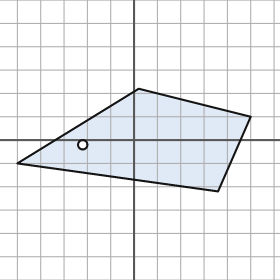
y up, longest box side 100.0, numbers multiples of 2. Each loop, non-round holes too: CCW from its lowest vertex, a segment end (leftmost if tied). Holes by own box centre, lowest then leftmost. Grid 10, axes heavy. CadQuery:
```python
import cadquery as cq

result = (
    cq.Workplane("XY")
    .moveTo(36.0, -22.0)
    .lineTo(50.0, 10.0)
    .lineTo(2.0, 22.0)
    .lineTo(-50.0, -10.0)
    .close()
    .moveTo(-22.0, -2.0)
    .circle(2.0)
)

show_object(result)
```